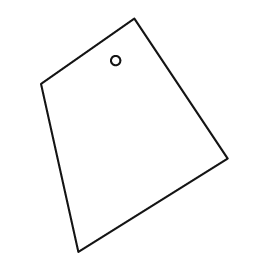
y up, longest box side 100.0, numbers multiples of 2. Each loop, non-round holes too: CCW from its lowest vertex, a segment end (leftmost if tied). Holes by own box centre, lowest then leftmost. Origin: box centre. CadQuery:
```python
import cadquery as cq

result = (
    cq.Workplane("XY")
    .moveTo(-24.0, -50.0)
    .lineTo(40.0, -10.0)
    .lineTo(0.0, 50.0)
    .lineTo(-40.0, 22.0)
    .close()
    .moveTo(-8.0, 32.0)
    .circle(2.0)
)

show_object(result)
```